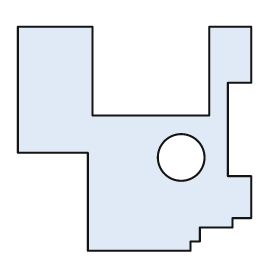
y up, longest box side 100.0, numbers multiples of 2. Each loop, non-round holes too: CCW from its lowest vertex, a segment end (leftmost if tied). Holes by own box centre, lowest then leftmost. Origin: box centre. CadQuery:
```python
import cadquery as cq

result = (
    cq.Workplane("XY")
    .moveTo(-20.0, -48.0)
    .lineTo(24.0, -48.0)
    .lineTo(24.0, -44.0)
    .lineTo(28.0, -44.0)
    .lineTo(28.0, -38.0)
    .lineTo(42.0, -38.0)
    .lineTo(42.0, -34.0)
    .lineTo(50.0, -34.0)
    .lineTo(50.0, -16.0)
    .lineTo(40.0, -16.0)
    .lineTo(40.0, 24.0)
    .lineTo(50.0, 24.0)
    .lineTo(50.0, 48.0)
    .lineTo(32.0, 48.0)
    .lineTo(32.0, 10.0)
    .lineTo(-18.0, 10.0)
    .lineTo(-18.0, 48.0)
    .lineTo(-50.0, 48.0)
    .lineTo(-50.0, -6.0)
    .lineTo(-20.0, -6.0)
    .close()
    .moveTo(20.0, -8.0)
    .circle(10.0)
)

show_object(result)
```